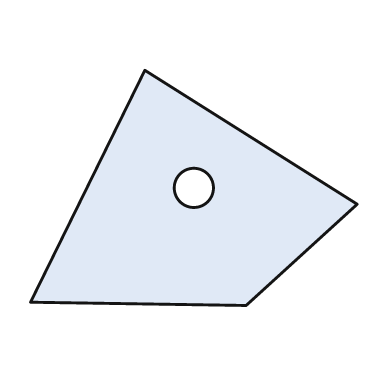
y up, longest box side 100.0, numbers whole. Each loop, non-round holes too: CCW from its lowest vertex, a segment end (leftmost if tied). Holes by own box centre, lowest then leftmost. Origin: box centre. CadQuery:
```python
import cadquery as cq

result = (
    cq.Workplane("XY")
    .moveTo(16.0, -36.0)
    .lineTo(50.0, -5.0)
    .lineTo(-15.0, 36.0)
    .lineTo(-50.0, -35.0)
    .close()
    .moveTo(0.0, 0.0)
    .circle(6.0)
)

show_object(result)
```